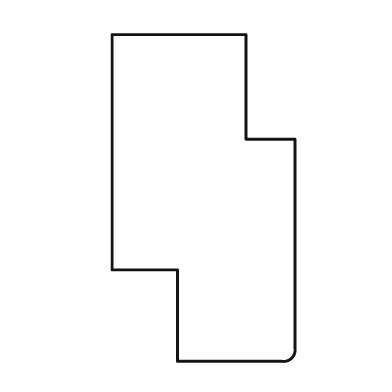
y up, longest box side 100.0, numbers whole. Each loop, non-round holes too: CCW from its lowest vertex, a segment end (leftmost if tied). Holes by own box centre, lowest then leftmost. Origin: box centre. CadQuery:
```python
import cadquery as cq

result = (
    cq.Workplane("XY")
    .moveTo(-8.0, -50.0)
    .lineTo(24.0, -50.0)
    .threePointArc((27.0, -49.0), (28.0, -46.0))
    .lineTo(28.0, 18.0)
    .lineTo(13.0, 18.0)
    .lineTo(13.0, 50.0)
    .lineTo(-28.0, 50.0)
    .lineTo(-28.0, -22.0)
    .lineTo(-8.0, -22.0)
    .close()
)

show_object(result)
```